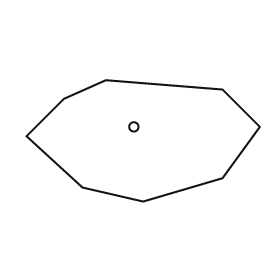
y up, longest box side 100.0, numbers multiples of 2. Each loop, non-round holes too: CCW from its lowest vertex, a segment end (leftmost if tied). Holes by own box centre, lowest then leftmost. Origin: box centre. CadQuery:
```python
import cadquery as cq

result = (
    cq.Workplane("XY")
    .moveTo(0.0, -26.0)
    .lineTo(34.0, -16.0)
    .lineTo(50.0, 6.0)
    .lineTo(34.0, 22.0)
    .lineTo(-16.0, 26.0)
    .lineTo(-34.0, 18.0)
    .lineTo(-50.0, 2.0)
    .lineTo(-26.0, -20.0)
    .close()
    .moveTo(-4.0, 6.0)
    .circle(2.0)
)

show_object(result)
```